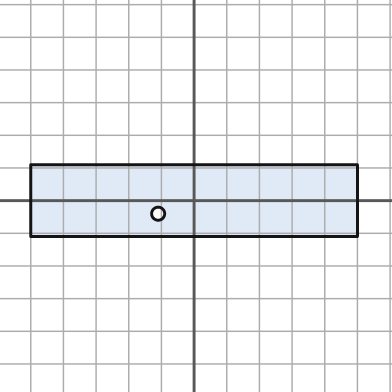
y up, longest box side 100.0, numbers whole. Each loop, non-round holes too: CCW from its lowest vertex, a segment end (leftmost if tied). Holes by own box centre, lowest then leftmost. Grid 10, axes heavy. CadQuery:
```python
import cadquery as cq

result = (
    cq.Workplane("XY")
    .moveTo(-50.0, -11.0)
    .lineTo(50.0, -11.0)
    .lineTo(50.0, 11.0)
    .lineTo(-50.0, 11.0)
    .close()
    .moveTo(-11.0, -4.0)
    .circle(2.0)
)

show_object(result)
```